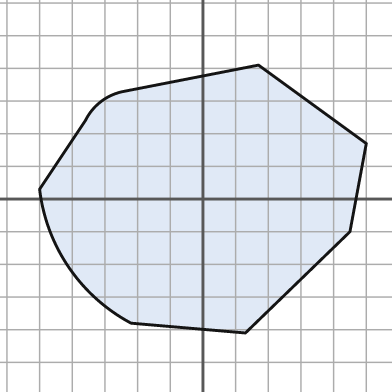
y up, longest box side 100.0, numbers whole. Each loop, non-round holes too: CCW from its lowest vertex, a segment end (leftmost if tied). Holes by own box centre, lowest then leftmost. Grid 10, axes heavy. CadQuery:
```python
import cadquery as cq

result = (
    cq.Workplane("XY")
    .moveTo(13.0, -41.0)
    .lineTo(45.0, -10.0)
    .lineTo(50.0, 17.0)
    .lineTo(17.0, 41.0)
    .lineTo(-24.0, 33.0)
    .threePointArc((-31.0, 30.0), (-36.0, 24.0))
    .lineTo(-50.0, 3.0)
    .threePointArc((-41.0, -21.0), (-22.0, -38.0))
    .close()
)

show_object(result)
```